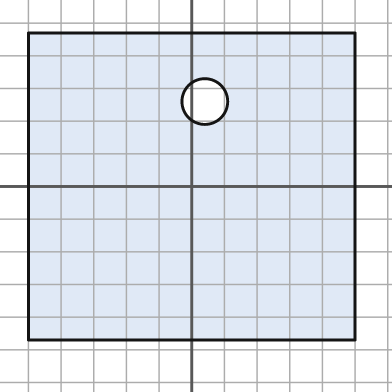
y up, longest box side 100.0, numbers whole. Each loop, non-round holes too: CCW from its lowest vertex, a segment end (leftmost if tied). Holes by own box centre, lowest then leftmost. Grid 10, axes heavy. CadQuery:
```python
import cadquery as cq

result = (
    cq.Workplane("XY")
    .moveTo(-50.0, -47.0)
    .lineTo(50.0, -47.0)
    .lineTo(50.0, 47.0)
    .lineTo(-50.0, 47.0)
    .close()
    .moveTo(4.0, 26.0)
    .circle(7.0)
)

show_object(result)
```